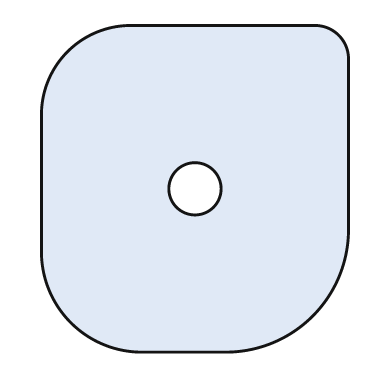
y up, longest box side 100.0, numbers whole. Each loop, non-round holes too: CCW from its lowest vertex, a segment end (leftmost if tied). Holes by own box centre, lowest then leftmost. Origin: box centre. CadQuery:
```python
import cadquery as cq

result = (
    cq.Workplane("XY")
    .moveTo(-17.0, -50.0)
    .lineTo(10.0, -50.0)
    .threePointArc((36.0, -39.0), (47.0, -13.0))
    .lineTo(47.0, 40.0)
    .threePointArc((44.0, 47.0), (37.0, 50.0))
    .lineTo(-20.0, 50.0)
    .threePointArc((-39.0, 42.0), (-47.0, 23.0))
    .lineTo(-47.0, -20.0)
    .threePointArc((-38.0, -41.0), (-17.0, -50.0))
    .close()
    .moveTo(0.0, 0.0)
    .circle(8.0)
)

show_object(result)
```